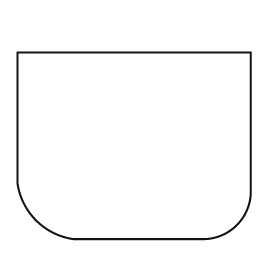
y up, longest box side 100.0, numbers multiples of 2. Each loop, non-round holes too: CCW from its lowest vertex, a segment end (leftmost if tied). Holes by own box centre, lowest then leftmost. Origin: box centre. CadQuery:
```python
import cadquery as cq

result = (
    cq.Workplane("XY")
    .moveTo(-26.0, -40.0)
    .lineTo(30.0, -40.0)
    .threePointArc((44.0, -34.0), (50.0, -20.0))
    .lineTo(50.0, 40.0)
    .lineTo(-50.0, 40.0)
    .lineTo(-50.0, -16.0)
    .threePointArc((-42.0, -32.0), (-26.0, -40.0))
    .close()
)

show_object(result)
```